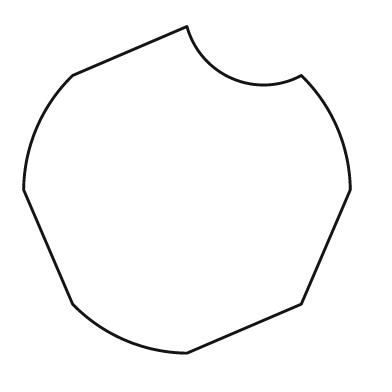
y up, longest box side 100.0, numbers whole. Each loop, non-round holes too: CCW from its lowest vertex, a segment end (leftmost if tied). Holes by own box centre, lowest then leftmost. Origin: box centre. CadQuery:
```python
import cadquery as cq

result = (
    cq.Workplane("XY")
    .moveTo(0.0, -50.0)
    .lineTo(35.0, -35.0)
    .lineTo(50.0, 0.0)
    .threePointArc((46.0, 19.0), (35.0, 35.0))
    .threePointArc((14.0, 34.0), (0.0, 50.0))
    .lineTo(-35.0, 35.0)
    .threePointArc((-46.0, 19.0), (-50.0, 0.0))
    .lineTo(-35.0, -35.0)
    .threePointArc((-19.0, -46.0), (0.0, -50.0))
    .close()
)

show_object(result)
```